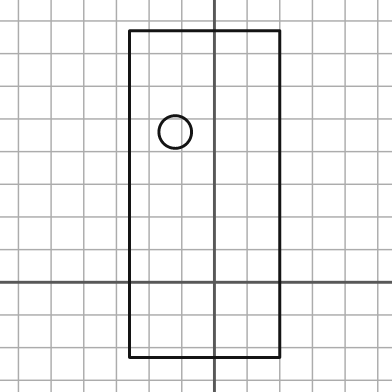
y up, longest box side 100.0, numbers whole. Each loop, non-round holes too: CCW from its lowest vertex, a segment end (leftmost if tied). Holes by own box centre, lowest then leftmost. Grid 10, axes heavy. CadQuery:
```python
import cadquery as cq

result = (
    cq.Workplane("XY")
    .moveTo(-26.0, -23.0)
    .lineTo(20.0, -23.0)
    .lineTo(20.0, 77.0)
    .lineTo(-26.0, 77.0)
    .close()
    .moveTo(-12.0, 46.0)
    .circle(5.0)
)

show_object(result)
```